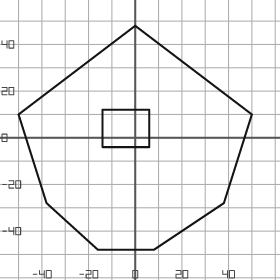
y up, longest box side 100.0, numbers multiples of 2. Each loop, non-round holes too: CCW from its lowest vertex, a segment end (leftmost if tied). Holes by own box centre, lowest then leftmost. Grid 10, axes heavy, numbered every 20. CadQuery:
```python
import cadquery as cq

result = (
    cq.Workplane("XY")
    .moveTo(-16.0, -48.0)
    .lineTo(8.0, -48.0)
    .lineTo(38.0, -28.0)
    .lineTo(50.0, 10.0)
    .lineTo(0.0, 48.0)
    .lineTo(-50.0, 10.0)
    .lineTo(-38.0, -28.0)
    .close()
    .moveTo(-14.0, -4.0)
    .lineTo(6.0, -4.0)
    .lineTo(6.0, 12.0)
    .lineTo(-14.0, 12.0)
    .close()
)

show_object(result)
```